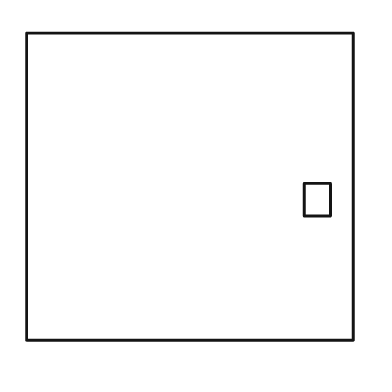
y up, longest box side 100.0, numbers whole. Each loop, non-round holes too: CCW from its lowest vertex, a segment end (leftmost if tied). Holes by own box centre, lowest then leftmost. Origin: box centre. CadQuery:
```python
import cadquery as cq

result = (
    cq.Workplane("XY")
    .moveTo(-50.0, -47.0)
    .lineTo(50.0, -47.0)
    .lineTo(50.0, 47.0)
    .lineTo(-50.0, 47.0)
    .close()
    .moveTo(35.0, -9.0)
    .lineTo(43.0, -9.0)
    .lineTo(43.0, 1.0)
    .lineTo(35.0, 1.0)
    .close()
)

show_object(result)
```